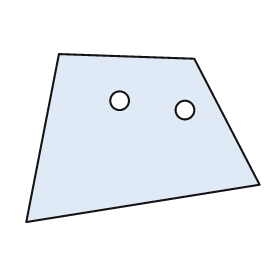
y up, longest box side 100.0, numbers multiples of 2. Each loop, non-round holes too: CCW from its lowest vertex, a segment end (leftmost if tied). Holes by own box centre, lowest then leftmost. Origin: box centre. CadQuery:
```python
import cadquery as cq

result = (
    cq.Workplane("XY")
    .moveTo(-50.0, -36.0)
    .lineTo(50.0, -20.0)
    .lineTo(22.0, 34.0)
    .lineTo(-36.0, 36.0)
    .close()
    .moveTo(18.0, 12.0)
    .circle(4.0)
    .moveTo(-10.0, 16.0)
    .circle(4.0)
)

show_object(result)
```